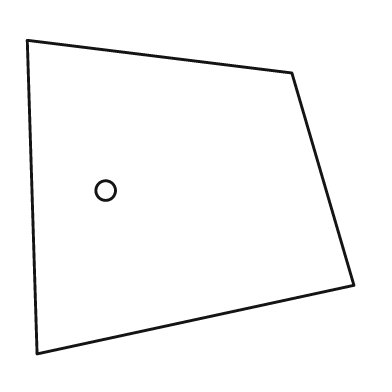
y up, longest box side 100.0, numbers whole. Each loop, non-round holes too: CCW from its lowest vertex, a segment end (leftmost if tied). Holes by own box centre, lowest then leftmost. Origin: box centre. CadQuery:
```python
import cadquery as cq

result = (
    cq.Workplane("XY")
    .moveTo(-47.0, -48.0)
    .lineTo(50.0, -27.0)
    .lineTo(31.0, 38.0)
    .lineTo(-50.0, 48.0)
    .close()
    .moveTo(-26.0, 2.0)
    .circle(3.0)
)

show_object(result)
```